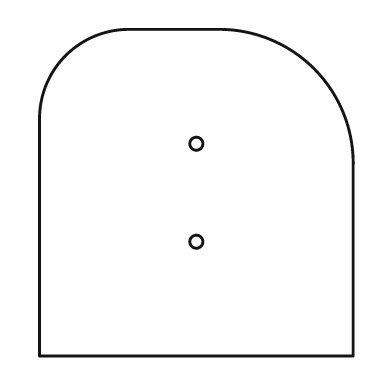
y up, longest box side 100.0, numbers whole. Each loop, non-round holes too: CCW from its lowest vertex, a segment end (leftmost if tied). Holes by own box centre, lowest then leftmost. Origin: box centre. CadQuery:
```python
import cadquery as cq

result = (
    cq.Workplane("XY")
    .moveTo(-48.0, -50.0)
    .lineTo(48.0, -50.0)
    .lineTo(48.0, 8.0)
    .threePointArc((36.0, 38.0), (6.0, 50.0))
    .lineTo(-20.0, 50.0)
    .threePointArc((-40.0, 42.0), (-48.0, 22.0))
    .close()
    .moveTo(0.0, -15.0)
    .circle(2.0)
    .moveTo(0.0, 15.0)
    .circle(2.0)
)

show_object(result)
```